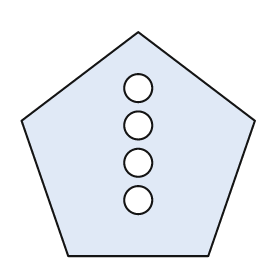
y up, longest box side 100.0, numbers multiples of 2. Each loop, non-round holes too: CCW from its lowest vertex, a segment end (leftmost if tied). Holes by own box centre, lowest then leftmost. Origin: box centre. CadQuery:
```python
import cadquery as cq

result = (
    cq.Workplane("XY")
    .moveTo(-30.0, -48.0)
    .lineTo(30.0, -48.0)
    .lineTo(50.0, 10.0)
    .lineTo(0.0, 48.0)
    .lineTo(-50.0, 10.0)
    .close()
    .moveTo(0.0, -24.0)
    .circle(6.0)
    .moveTo(0.0, -8.0)
    .circle(6.0)
    .moveTo(0.0, 8.0)
    .circle(6.0)
    .moveTo(0.0, 24.0)
    .circle(6.0)
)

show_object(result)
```